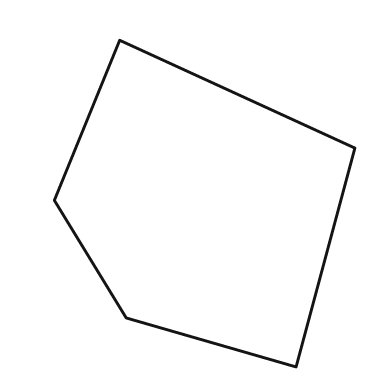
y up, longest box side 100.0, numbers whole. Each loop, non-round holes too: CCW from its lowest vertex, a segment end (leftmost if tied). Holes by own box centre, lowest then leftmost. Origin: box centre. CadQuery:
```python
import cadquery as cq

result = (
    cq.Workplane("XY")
    .moveTo(28.0, -50.0)
    .lineTo(46.0, 17.0)
    .lineTo(-26.0, 50.0)
    .lineTo(-46.0, 1.0)
    .lineTo(-24.0, -35.0)
    .close()
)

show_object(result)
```